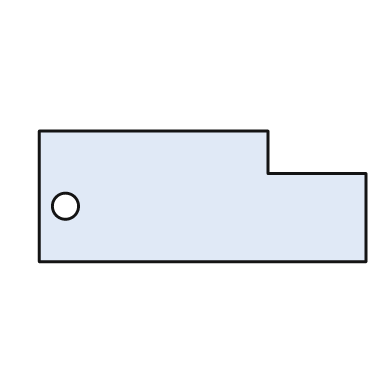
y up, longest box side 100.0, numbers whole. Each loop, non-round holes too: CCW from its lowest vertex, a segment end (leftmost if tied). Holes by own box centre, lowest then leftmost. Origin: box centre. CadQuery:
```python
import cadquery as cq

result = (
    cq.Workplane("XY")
    .moveTo(-50.0, -20.0)
    .lineTo(50.0, -20.0)
    .lineTo(50.0, 7.0)
    .lineTo(20.0, 7.0)
    .lineTo(20.0, 20.0)
    .lineTo(-50.0, 20.0)
    .close()
    .moveTo(-42.0, -3.0)
    .circle(4.0)
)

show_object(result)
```